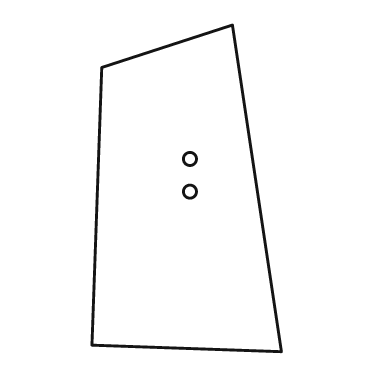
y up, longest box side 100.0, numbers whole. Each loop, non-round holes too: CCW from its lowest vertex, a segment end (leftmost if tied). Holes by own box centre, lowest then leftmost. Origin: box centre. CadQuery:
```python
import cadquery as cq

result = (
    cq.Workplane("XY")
    .moveTo(29.0, -50.0)
    .lineTo(14.0, 50.0)
    .lineTo(-26.0, 37.0)
    .lineTo(-29.0, -48.0)
    .close()
    .moveTo(1.0, -1.0)
    .circle(2.0)
    .moveTo(1.0, 9.0)
    .circle(2.0)
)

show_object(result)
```